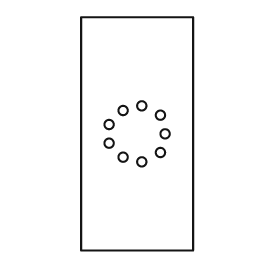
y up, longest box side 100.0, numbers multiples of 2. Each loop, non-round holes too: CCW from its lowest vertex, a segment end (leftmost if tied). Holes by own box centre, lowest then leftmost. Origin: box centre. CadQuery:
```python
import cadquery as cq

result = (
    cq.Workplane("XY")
    .moveTo(-24.0, -50.0)
    .lineTo(24.0, -50.0)
    .lineTo(24.0, 50.0)
    .lineTo(-24.0, 50.0)
    .close()
    .moveTo(2.0, -12.0)
    .circle(2.0)
    .moveTo(-6.0, -10.0)
    .circle(2.0)
    .moveTo(10.0, -8.0)
    .circle(2.0)
    .moveTo(-12.0, -4.0)
    .circle(2.0)
    .moveTo(12.0, 0.0)
    .circle(2.0)
    .moveTo(-12.0, 4.0)
    .circle(2.0)
    .moveTo(10.0, 8.0)
    .circle(2.0)
    .moveTo(-6.0, 10.0)
    .circle(2.0)
    .moveTo(2.0, 12.0)
    .circle(2.0)
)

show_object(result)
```